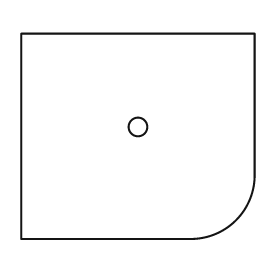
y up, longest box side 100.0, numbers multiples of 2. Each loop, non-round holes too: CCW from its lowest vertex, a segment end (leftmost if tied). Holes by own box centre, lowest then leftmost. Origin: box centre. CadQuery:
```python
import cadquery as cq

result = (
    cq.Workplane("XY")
    .moveTo(-50.0, -44.0)
    .lineTo(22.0, -44.0)
    .threePointArc((42.0, -36.0), (50.0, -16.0))
    .lineTo(50.0, 44.0)
    .lineTo(-50.0, 44.0)
    .close()
    .moveTo(0.0, 4.0)
    .circle(4.0)
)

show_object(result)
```